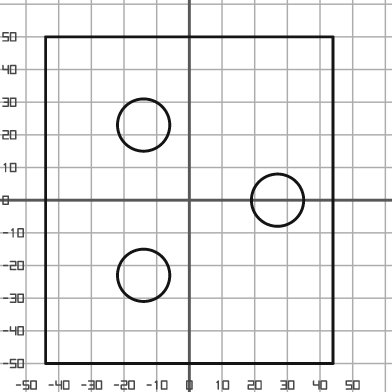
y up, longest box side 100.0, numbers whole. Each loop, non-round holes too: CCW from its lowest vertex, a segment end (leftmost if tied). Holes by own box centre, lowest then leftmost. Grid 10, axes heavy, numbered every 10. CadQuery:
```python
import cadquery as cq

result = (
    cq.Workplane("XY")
    .moveTo(-44.0, -50.0)
    .lineTo(44.0, -50.0)
    .lineTo(44.0, 50.0)
    .lineTo(-44.0, 50.0)
    .close()
    .moveTo(-14.0, -23.0)
    .circle(8.0)
    .moveTo(27.0, 0.0)
    .circle(8.0)
    .moveTo(-14.0, 23.0)
    .circle(8.0)
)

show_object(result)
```